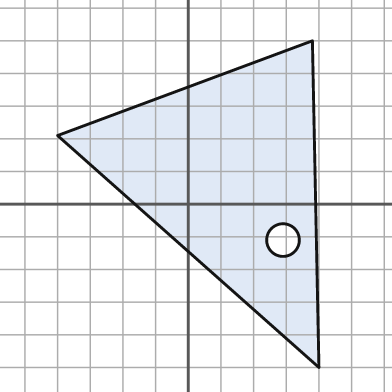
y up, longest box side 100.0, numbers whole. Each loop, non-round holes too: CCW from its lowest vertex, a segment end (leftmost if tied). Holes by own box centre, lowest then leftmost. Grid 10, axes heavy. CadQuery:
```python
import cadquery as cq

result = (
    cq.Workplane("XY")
    .moveTo(40.0, -50.0)
    .lineTo(38.0, 50.0)
    .lineTo(-40.0, 21.0)
    .close()
    .moveTo(29.0, -11.0)
    .circle(5.0)
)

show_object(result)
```